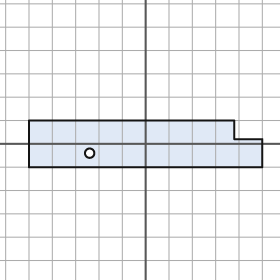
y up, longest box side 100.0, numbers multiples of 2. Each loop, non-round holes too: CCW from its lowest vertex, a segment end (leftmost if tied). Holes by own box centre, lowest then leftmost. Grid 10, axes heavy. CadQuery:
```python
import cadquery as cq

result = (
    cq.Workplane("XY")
    .moveTo(-50.0, -10.0)
    .lineTo(50.0, -10.0)
    .lineTo(50.0, 2.0)
    .lineTo(38.0, 2.0)
    .lineTo(38.0, 10.0)
    .lineTo(-50.0, 10.0)
    .close()
    .moveTo(-24.0, -4.0)
    .circle(2.0)
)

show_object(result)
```